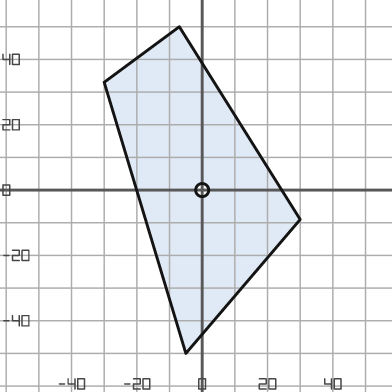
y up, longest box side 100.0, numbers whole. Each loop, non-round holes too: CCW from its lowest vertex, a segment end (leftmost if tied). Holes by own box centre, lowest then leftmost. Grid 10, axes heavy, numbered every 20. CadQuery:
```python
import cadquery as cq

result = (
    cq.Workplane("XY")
    .moveTo(-5.0, -50.0)
    .lineTo(30.0, -9.0)
    .lineTo(-7.0, 50.0)
    .lineTo(-30.0, 33.0)
    .close()
    .moveTo(0.0, 0.0)
    .circle(2.0)
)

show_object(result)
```